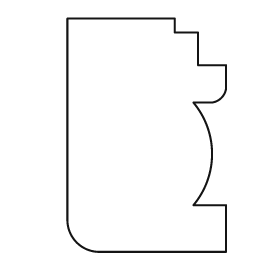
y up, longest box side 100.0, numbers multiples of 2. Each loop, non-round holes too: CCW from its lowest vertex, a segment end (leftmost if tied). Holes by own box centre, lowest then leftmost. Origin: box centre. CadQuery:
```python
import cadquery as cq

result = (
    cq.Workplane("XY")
    .moveTo(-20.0, -50.0)
    .lineTo(34.0, -50.0)
    .lineTo(34.0, -30.0)
    .lineTo(20.0, -30.0)
    .threePointArc((28.0, -8.0), (20.0, 14.0))
    .lineTo(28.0, 14.0)
    .threePointArc((32.0, 16.0), (34.0, 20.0))
    .lineTo(34.0, 30.0)
    .lineTo(22.0, 30.0)
    .lineTo(22.0, 44.0)
    .lineTo(12.0, 44.0)
    .lineTo(12.0, 50.0)
    .lineTo(-34.0, 50.0)
    .lineTo(-34.0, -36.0)
    .threePointArc((-30.0, -46.0), (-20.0, -50.0))
    .close()
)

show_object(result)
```